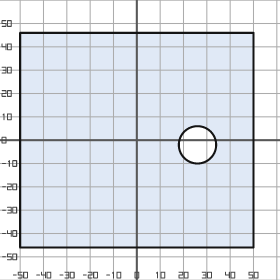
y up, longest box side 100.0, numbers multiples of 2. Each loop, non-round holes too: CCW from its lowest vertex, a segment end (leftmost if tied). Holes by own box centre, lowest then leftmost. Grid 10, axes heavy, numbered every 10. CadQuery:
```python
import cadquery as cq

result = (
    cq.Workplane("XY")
    .moveTo(-50.0, -46.0)
    .lineTo(50.0, -46.0)
    .lineTo(50.0, 46.0)
    .lineTo(-50.0, 46.0)
    .close()
    .moveTo(26.0, -2.0)
    .circle(8.0)
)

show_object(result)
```